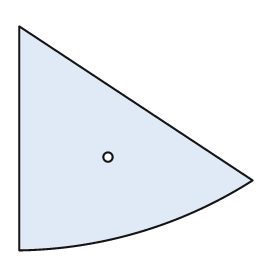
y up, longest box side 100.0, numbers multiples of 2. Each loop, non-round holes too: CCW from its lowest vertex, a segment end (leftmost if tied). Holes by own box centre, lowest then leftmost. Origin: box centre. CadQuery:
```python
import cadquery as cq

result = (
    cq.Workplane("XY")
    .moveTo(-50.0, -48.0)
    .threePointArc((2.0, -40.0), (50.0, -18.0))
    .lineTo(-50.0, 48.0)
    .close()
    .moveTo(-12.0, -8.0)
    .circle(2.0)
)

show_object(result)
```